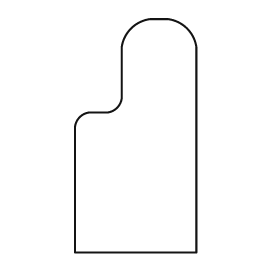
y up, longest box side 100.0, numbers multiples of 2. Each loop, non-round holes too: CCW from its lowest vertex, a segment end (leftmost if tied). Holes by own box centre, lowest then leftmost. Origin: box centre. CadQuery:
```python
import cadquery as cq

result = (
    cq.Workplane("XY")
    .moveTo(-26.0, -50.0)
    .lineTo(26.0, -50.0)
    .lineTo(26.0, 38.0)
    .threePointArc((22.0, 46.0), (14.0, 50.0))
    .lineTo(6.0, 50.0)
    .threePointArc((-2.0, 46.0), (-6.0, 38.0))
    .lineTo(-6.0, 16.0)
    .threePointArc((-8.0, 12.0), (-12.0, 10.0))
    .lineTo(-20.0, 10.0)
    .threePointArc((-24.0, 8.0), (-26.0, 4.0))
    .close()
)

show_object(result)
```